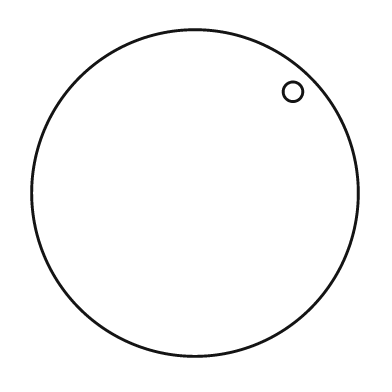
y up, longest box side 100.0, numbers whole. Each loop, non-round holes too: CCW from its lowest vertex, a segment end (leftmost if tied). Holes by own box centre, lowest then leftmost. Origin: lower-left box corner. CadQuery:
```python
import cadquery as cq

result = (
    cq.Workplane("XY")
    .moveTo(50.0, 50.0)
    .circle(50.0)
    .moveTo(80.0, 81.0)
    .circle(3.0)
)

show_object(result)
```